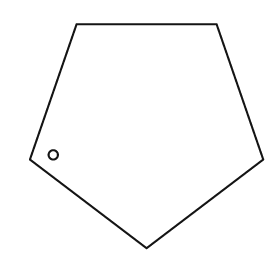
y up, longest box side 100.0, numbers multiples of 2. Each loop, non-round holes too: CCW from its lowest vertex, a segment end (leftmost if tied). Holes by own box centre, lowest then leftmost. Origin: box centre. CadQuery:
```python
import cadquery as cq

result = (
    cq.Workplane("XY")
    .moveTo(0.0, -48.0)
    .lineTo(50.0, -10.0)
    .lineTo(30.0, 48.0)
    .lineTo(-30.0, 48.0)
    .lineTo(-50.0, -10.0)
    .close()
    .moveTo(-40.0, -8.0)
    .circle(2.0)
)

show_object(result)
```